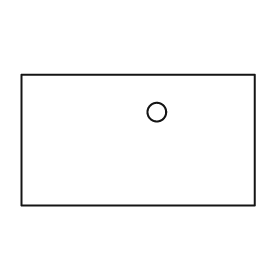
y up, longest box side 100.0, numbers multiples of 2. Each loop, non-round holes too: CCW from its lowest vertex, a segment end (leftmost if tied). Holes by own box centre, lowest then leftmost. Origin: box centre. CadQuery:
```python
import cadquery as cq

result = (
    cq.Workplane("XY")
    .moveTo(-50.0, -28.0)
    .lineTo(50.0, -28.0)
    .lineTo(50.0, 28.0)
    .lineTo(-50.0, 28.0)
    .close()
    .moveTo(8.0, 12.0)
    .circle(4.0)
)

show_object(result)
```